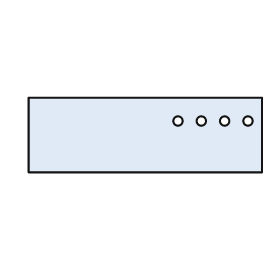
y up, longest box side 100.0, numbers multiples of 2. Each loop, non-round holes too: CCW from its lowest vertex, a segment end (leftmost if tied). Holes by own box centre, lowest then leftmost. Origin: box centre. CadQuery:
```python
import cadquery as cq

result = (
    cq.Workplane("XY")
    .moveTo(-50.0, -16.0)
    .lineTo(50.0, -16.0)
    .lineTo(50.0, 16.0)
    .lineTo(-50.0, 16.0)
    .close()
    .moveTo(14.0, 6.0)
    .circle(2.0)
    .moveTo(24.0, 6.0)
    .circle(2.0)
    .moveTo(34.0, 6.0)
    .circle(2.0)
    .moveTo(44.0, 6.0)
    .circle(2.0)
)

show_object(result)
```